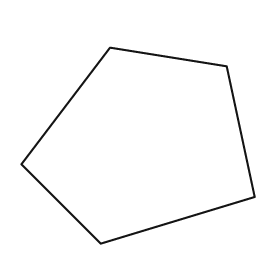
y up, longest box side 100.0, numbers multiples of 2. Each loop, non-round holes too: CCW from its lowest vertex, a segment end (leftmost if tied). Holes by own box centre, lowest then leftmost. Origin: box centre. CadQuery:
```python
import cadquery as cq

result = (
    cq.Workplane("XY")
    .moveTo(-16.0, -42.0)
    .lineTo(50.0, -22.0)
    .lineTo(38.0, 34.0)
    .lineTo(-12.0, 42.0)
    .lineTo(-50.0, -8.0)
    .close()
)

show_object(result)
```